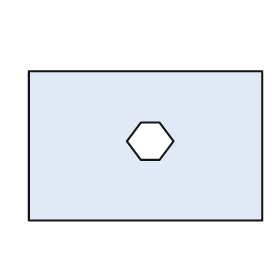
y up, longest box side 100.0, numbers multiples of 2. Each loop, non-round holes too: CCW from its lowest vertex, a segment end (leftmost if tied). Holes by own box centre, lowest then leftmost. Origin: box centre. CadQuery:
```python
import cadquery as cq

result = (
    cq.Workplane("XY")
    .moveTo(-50.0, -32.0)
    .lineTo(50.0, -32.0)
    .lineTo(50.0, 32.0)
    .lineTo(-50.0, 32.0)
    .close()
    .moveTo(-2.0, -6.0)
    .lineTo(6.0, -6.0)
    .lineTo(12.0, 2.0)
    .lineTo(6.0, 10.0)
    .lineTo(-2.0, 10.0)
    .lineTo(-8.0, 2.0)
    .close()
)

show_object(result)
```